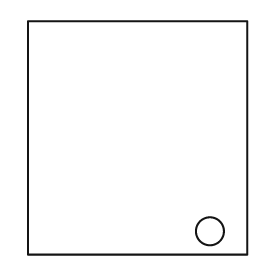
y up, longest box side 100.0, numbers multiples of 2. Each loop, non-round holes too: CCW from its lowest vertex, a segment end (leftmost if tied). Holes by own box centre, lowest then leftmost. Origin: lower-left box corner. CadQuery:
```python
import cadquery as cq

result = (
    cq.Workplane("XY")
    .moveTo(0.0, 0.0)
    .lineTo(94.0, 0.0)
    .lineTo(94.0, 100.0)
    .lineTo(0.0, 100.0)
    .close()
    .moveTo(78.0, 10.0)
    .circle(6.0)
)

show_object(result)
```